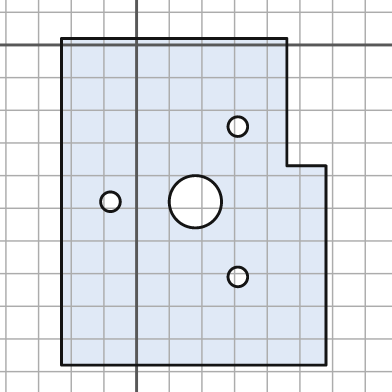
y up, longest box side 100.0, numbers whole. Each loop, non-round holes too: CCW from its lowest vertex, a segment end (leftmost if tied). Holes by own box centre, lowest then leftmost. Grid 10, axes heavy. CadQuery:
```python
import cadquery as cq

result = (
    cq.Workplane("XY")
    .moveTo(-23.0, -98.0)
    .lineTo(58.0, -98.0)
    .lineTo(58.0, -37.0)
    .lineTo(46.0, -37.0)
    .lineTo(46.0, 2.0)
    .lineTo(-23.0, 2.0)
    .close()
    .moveTo(31.0, -71.0)
    .circle(3.0)
    .moveTo(-8.0, -48.0)
    .circle(3.0)
    .moveTo(18.0, -48.0)
    .circle(8.0)
    .moveTo(31.0, -25.0)
    .circle(3.0)
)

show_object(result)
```